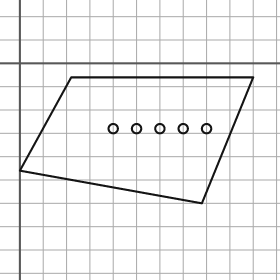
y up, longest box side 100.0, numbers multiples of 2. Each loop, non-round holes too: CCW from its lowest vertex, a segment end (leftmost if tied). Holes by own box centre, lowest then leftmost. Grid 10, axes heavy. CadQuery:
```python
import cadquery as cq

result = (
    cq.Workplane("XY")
    .moveTo(78.0, -60.0)
    .lineTo(100.0, -6.0)
    .lineTo(22.0, -6.0)
    .lineTo(0.0, -46.0)
    .close()
    .moveTo(40.0, -28.0)
    .circle(2.0)
    .moveTo(50.0, -28.0)
    .circle(2.0)
    .moveTo(60.0, -28.0)
    .circle(2.0)
    .moveTo(70.0, -28.0)
    .circle(2.0)
    .moveTo(80.0, -28.0)
    .circle(2.0)
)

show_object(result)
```